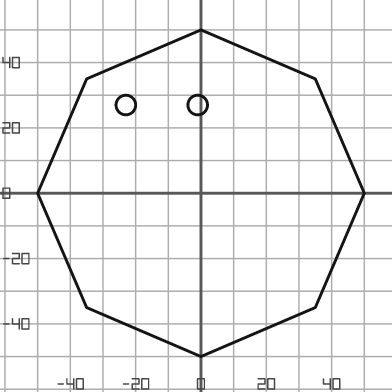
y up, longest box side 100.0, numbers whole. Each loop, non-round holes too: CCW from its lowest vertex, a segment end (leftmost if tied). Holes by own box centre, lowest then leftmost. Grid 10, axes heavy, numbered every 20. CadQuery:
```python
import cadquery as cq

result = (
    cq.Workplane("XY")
    .moveTo(0.0, -50.0)
    .lineTo(35.0, -35.0)
    .lineTo(50.0, 0.0)
    .lineTo(35.0, 35.0)
    .lineTo(0.0, 50.0)
    .lineTo(-35.0, 35.0)
    .lineTo(-50.0, 0.0)
    .lineTo(-35.0, -35.0)
    .close()
    .moveTo(-23.0, 27.0)
    .circle(3.0)
    .moveTo(-1.0, 27.0)
    .circle(3.0)
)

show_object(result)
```